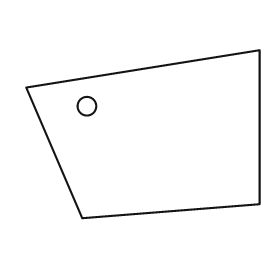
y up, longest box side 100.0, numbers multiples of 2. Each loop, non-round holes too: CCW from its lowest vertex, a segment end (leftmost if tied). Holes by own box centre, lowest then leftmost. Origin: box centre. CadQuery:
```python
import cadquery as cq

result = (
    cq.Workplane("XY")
    .moveTo(-26.0, -36.0)
    .lineTo(50.0, -30.0)
    .lineTo(50.0, 36.0)
    .lineTo(-50.0, 20.0)
    .close()
    .moveTo(-24.0, 12.0)
    .circle(4.0)
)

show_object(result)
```